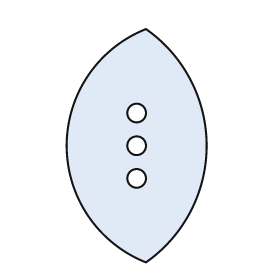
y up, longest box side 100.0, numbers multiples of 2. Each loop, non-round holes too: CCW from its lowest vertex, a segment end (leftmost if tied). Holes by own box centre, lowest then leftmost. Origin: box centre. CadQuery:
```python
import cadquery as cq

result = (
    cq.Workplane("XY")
    .moveTo(4.0, -50.0)
    .threePointArc((30.0, 0.0), (4.0, 50.0))
    .threePointArc((-30.0, 0.0), (4.0, -50.0))
    .close()
    .moveTo(0.0, -14.0)
    .circle(4.0)
    .moveTo(0.0, 0.0)
    .circle(4.0)
    .moveTo(0.0, 14.0)
    .circle(4.0)
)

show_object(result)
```